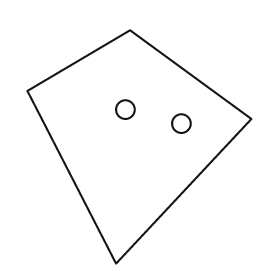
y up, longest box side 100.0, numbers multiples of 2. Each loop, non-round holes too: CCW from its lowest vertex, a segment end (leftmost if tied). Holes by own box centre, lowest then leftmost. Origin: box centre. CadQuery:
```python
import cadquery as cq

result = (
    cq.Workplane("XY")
    .moveTo(-10.0, -50.0)
    .lineTo(48.0, 12.0)
    .lineTo(-4.0, 50.0)
    .lineTo(-48.0, 24.0)
    .close()
    .moveTo(18.0, 10.0)
    .circle(4.0)
    .moveTo(-6.0, 16.0)
    .circle(4.0)
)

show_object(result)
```